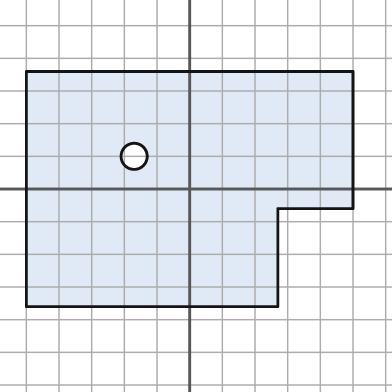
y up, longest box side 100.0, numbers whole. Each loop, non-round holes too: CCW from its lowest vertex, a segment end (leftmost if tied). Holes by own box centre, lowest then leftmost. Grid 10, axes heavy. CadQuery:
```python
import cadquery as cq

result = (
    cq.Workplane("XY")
    .moveTo(-50.0, -36.0)
    .lineTo(27.0, -36.0)
    .lineTo(27.0, -6.0)
    .lineTo(50.0, -6.0)
    .lineTo(50.0, 36.0)
    .lineTo(-50.0, 36.0)
    .close()
    .moveTo(-17.0, 10.0)
    .circle(4.0)
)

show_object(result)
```